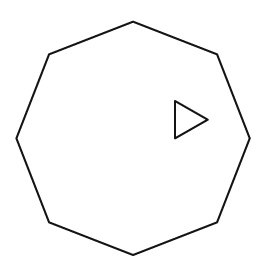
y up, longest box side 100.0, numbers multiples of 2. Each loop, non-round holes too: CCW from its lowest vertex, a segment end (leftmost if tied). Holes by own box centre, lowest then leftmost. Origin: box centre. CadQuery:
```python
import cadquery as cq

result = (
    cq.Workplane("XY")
    .moveTo(0.0, -50.0)
    .lineTo(36.0, -36.0)
    .lineTo(50.0, 0.0)
    .lineTo(36.0, 36.0)
    .lineTo(0.0, 50.0)
    .lineTo(-36.0, 36.0)
    .lineTo(-50.0, 0.0)
    .lineTo(-36.0, -36.0)
    .close()
    .moveTo(18.0, 0.0)
    .lineTo(32.0, 8.0)
    .lineTo(18.0, 16.0)
    .close()
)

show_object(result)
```